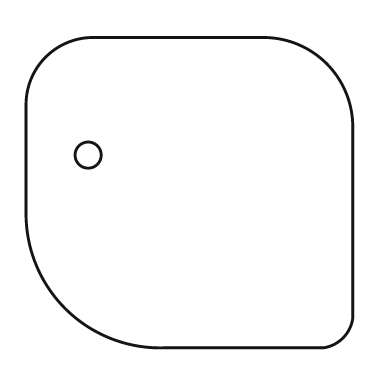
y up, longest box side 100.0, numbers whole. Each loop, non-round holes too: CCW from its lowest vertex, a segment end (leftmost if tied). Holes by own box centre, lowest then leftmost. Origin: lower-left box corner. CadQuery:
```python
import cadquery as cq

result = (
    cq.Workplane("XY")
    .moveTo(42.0, 0.0)
    .lineTo(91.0, 0.0)
    .threePointArc((97.0, 3.0), (100.0, 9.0))
    .lineTo(100.0, 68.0)
    .threePointArc((92.0, 87.0), (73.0, 95.0))
    .lineTo(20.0, 95.0)
    .threePointArc((6.0, 89.0), (0.0, 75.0))
    .lineTo(0.0, 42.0)
    .threePointArc((12.0, 12.0), (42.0, 0.0))
    .close()
    .moveTo(19.0, 59.0)
    .circle(4.0)
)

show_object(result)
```